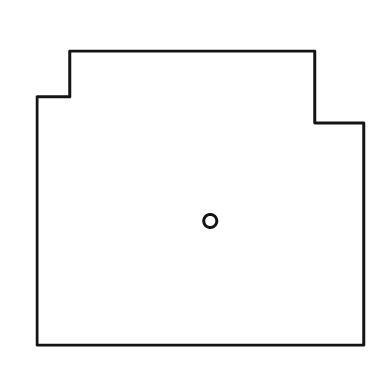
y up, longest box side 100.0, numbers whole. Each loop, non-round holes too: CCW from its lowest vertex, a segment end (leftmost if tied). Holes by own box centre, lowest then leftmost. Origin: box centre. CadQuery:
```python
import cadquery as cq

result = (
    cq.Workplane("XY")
    .moveTo(-50.0, -45.0)
    .lineTo(50.0, -45.0)
    .lineTo(50.0, 23.0)
    .lineTo(35.0, 23.0)
    .lineTo(35.0, 45.0)
    .lineTo(-40.0, 45.0)
    .lineTo(-40.0, 31.0)
    .lineTo(-50.0, 31.0)
    .close()
    .moveTo(3.0, -7.0)
    .circle(2.0)
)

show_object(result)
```